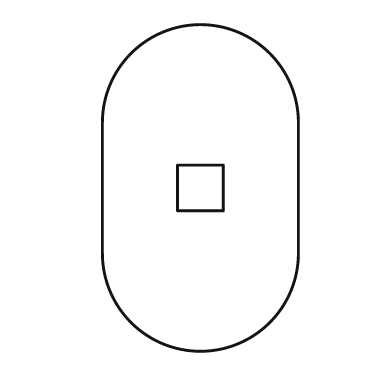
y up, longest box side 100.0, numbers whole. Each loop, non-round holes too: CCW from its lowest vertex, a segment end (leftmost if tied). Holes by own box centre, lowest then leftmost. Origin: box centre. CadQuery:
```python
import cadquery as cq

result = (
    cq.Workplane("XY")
    .moveTo(-30.0, -20.0)
    .threePointArc((0.0, -50.0), (30.0, -20.0))
    .lineTo(30.0, 20.0)
    .threePointArc((0.0, 50.0), (-30.0, 20.0))
    .close()
    .moveTo(-7.0, -7.0)
    .lineTo(7.0, -7.0)
    .lineTo(7.0, 7.0)
    .lineTo(-7.0, 7.0)
    .close()
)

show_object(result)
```